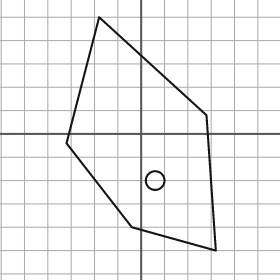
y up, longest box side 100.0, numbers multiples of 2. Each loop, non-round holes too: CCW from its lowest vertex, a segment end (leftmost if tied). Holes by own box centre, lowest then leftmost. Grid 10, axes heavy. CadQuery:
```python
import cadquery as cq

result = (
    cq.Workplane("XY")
    .moveTo(32.0, -50.0)
    .lineTo(28.0, 8.0)
    .lineTo(-18.0, 50.0)
    .lineTo(-32.0, -4.0)
    .lineTo(-4.0, -40.0)
    .close()
    .moveTo(6.0, -20.0)
    .circle(4.0)
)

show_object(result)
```